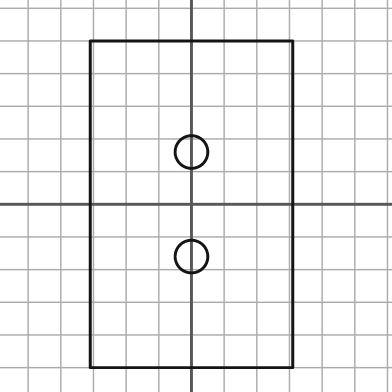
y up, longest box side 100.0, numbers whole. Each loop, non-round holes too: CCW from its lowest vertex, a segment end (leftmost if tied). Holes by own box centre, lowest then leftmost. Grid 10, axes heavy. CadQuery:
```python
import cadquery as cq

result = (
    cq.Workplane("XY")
    .moveTo(-31.0, -50.0)
    .lineTo(31.0, -50.0)
    .lineTo(31.0, 50.0)
    .lineTo(-31.0, 50.0)
    .close()
    .moveTo(0.0, -16.0)
    .circle(5.0)
    .moveTo(0.0, 16.0)
    .circle(5.0)
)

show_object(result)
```